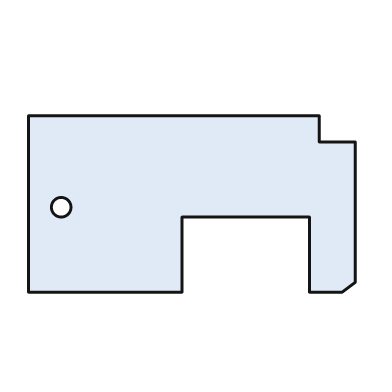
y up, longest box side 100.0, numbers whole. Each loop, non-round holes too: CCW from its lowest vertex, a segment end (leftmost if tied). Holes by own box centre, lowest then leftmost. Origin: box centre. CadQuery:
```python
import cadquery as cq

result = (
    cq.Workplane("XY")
    .moveTo(-50.0, -27.0)
    .lineTo(-3.0, -27.0)
    .lineTo(-3.0, -4.0)
    .lineTo(36.0, -4.0)
    .lineTo(36.0, -27.0)
    .lineTo(46.0, -27.0)
    .lineTo(50.0, -24.0)
    .lineTo(50.0, 19.0)
    .lineTo(39.0, 19.0)
    .lineTo(39.0, 27.0)
    .lineTo(-50.0, 27.0)
    .close()
    .moveTo(-40.0, -1.0)
    .circle(3.0)
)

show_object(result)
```